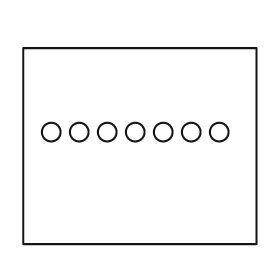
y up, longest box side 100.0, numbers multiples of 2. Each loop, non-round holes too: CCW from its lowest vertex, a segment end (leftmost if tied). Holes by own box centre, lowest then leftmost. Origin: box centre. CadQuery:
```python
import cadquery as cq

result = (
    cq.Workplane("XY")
    .moveTo(-50.0, -42.0)
    .lineTo(50.0, -42.0)
    .lineTo(50.0, 42.0)
    .lineTo(-50.0, 42.0)
    .close()
    .moveTo(-38.0, 6.0)
    .circle(4.0)
    .moveTo(-26.0, 6.0)
    .circle(4.0)
    .moveTo(-14.0, 6.0)
    .circle(4.0)
    .moveTo(-2.0, 6.0)
    .circle(4.0)
    .moveTo(10.0, 6.0)
    .circle(4.0)
    .moveTo(22.0, 6.0)
    .circle(4.0)
    .moveTo(34.0, 6.0)
    .circle(4.0)
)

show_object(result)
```